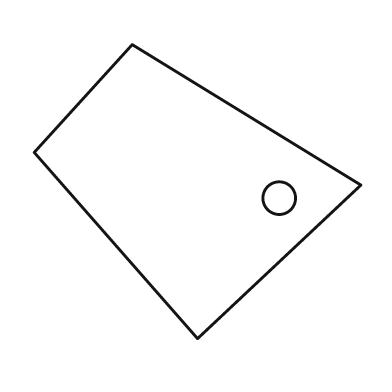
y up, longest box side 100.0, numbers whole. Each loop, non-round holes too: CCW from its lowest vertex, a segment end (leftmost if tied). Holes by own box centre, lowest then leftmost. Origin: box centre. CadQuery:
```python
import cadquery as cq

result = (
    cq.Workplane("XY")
    .moveTo(0.0, -45.0)
    .lineTo(50.0, 2.0)
    .lineTo(-20.0, 45.0)
    .lineTo(-50.0, 12.0)
    .close()
    .moveTo(25.0, -2.0)
    .circle(5.0)
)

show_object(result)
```